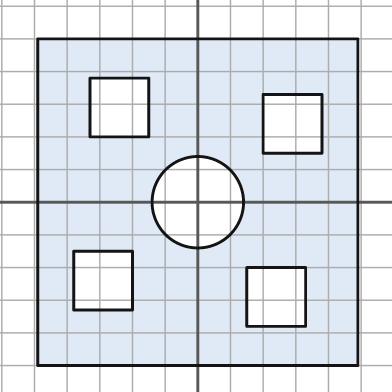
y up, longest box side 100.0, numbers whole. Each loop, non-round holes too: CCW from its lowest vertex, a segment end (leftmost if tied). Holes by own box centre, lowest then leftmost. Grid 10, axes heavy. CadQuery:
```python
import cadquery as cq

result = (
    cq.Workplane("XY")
    .moveTo(-49.0, -50.0)
    .lineTo(49.0, -50.0)
    .lineTo(49.0, 50.0)
    .lineTo(-49.0, 50.0)
    .close()
    .moveTo(15.0, -38.0)
    .lineTo(33.0, -38.0)
    .lineTo(33.0, -20.0)
    .lineTo(15.0, -20.0)
    .close()
    .moveTo(-38.0, -33.0)
    .lineTo(-20.0, -33.0)
    .lineTo(-20.0, -15.0)
    .lineTo(-38.0, -15.0)
    .close()
    .moveTo(0.0, 0.0)
    .circle(14.0)
    .moveTo(20.0, 15.0)
    .lineTo(38.0, 15.0)
    .lineTo(38.0, 33.0)
    .lineTo(20.0, 33.0)
    .close()
    .moveTo(-33.0, 20.0)
    .lineTo(-15.0, 20.0)
    .lineTo(-15.0, 38.0)
    .lineTo(-33.0, 38.0)
    .close()
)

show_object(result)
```